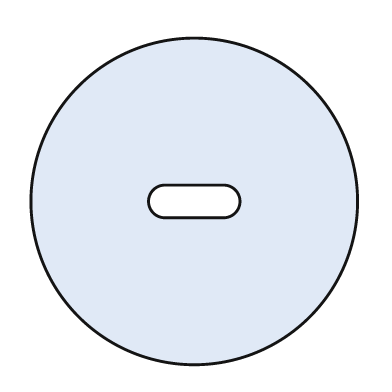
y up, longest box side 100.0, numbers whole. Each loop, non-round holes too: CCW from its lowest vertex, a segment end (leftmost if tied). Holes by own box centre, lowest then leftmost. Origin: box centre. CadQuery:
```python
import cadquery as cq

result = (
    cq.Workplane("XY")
    .moveTo(0.0, 0.0)
    .circle(50.0)
    .moveTo(-9.0, -5.0)
    .lineTo(9.0, -5.0)
    .threePointArc((14.0, 0.0), (9.0, 5.0))
    .lineTo(-9.0, 5.0)
    .threePointArc((-14.0, 0.0), (-9.0, -5.0))
    .close()
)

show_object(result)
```